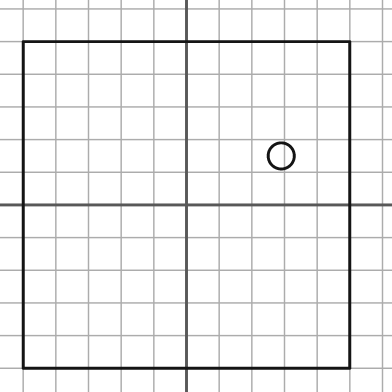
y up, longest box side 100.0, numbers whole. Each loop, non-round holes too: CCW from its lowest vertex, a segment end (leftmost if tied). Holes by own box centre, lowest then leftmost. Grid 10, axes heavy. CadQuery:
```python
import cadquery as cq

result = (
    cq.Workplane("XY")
    .moveTo(-50.0, -50.0)
    .lineTo(50.0, -50.0)
    .lineTo(50.0, 50.0)
    .lineTo(-50.0, 50.0)
    .close()
    .moveTo(29.0, 15.0)
    .circle(4.0)
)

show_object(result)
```